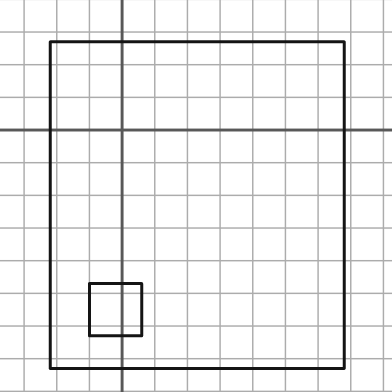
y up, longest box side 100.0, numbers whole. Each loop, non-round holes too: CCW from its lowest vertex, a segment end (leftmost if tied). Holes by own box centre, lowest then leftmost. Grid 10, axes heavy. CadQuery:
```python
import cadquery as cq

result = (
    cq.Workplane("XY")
    .moveTo(-22.0, -73.0)
    .lineTo(68.0, -73.0)
    .lineTo(68.0, 27.0)
    .lineTo(-22.0, 27.0)
    .close()
    .moveTo(-10.0, -63.0)
    .lineTo(6.0, -63.0)
    .lineTo(6.0, -47.0)
    .lineTo(-10.0, -47.0)
    .close()
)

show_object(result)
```